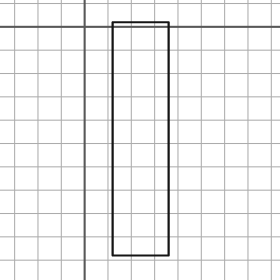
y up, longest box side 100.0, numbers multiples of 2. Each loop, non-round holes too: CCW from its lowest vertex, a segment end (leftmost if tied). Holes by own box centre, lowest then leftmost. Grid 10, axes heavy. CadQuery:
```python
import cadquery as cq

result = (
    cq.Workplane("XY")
    .moveTo(12.0, -98.0)
    .lineTo(36.0, -98.0)
    .lineTo(36.0, 2.0)
    .lineTo(12.0, 2.0)
    .close()
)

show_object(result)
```